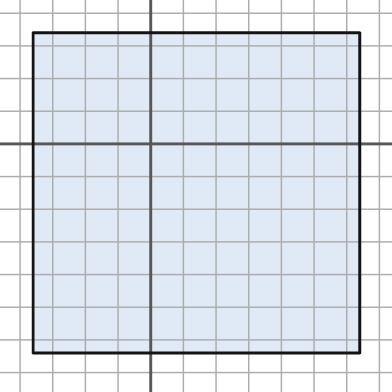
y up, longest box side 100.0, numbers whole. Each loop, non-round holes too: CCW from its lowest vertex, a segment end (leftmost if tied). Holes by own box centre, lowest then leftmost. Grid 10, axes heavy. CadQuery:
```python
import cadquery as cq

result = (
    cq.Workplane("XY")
    .moveTo(-36.0, -64.0)
    .lineTo(64.0, -64.0)
    .lineTo(64.0, 34.0)
    .lineTo(-36.0, 34.0)
    .close()
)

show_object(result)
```